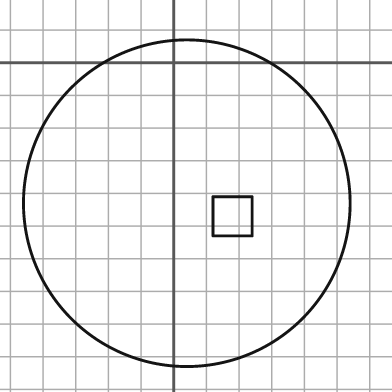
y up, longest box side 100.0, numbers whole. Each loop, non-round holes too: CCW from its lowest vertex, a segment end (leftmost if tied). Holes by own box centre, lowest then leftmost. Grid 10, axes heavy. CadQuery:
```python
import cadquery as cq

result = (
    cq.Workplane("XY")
    .moveTo(4.0, -43.0)
    .circle(50.0)
    .moveTo(12.0, -53.0)
    .lineTo(24.0, -53.0)
    .lineTo(24.0, -41.0)
    .lineTo(12.0, -41.0)
    .close()
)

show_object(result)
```